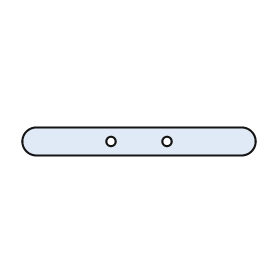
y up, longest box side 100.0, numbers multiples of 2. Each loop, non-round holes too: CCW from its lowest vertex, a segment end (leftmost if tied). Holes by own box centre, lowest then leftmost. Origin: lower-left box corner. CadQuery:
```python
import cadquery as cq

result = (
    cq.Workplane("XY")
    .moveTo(6.0, 0.0)
    .lineTo(94.0, 0.0)
    .threePointArc((100.0, 6.0), (94.0, 12.0))
    .lineTo(6.0, 12.0)
    .threePointArc((0.0, 6.0), (6.0, 0.0))
    .close()
    .moveTo(38.0, 6.0)
    .circle(2.0)
    .moveTo(62.0, 6.0)
    .circle(2.0)
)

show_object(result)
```